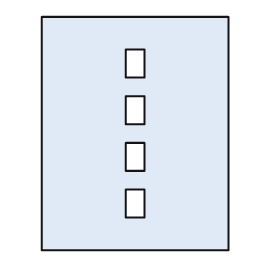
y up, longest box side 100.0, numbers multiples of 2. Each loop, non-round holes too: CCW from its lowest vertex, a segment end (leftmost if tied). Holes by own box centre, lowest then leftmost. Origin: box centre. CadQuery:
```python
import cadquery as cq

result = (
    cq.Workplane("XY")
    .moveTo(-40.0, -50.0)
    .lineTo(40.0, -50.0)
    .lineTo(40.0, 50.0)
    .lineTo(-40.0, 50.0)
    .close()
    .moveTo(-4.0, -36.0)
    .lineTo(4.0, -36.0)
    .lineTo(4.0, -24.0)
    .lineTo(-4.0, -24.0)
    .close()
    .moveTo(-4.0, -16.0)
    .lineTo(4.0, -16.0)
    .lineTo(4.0, -4.0)
    .lineTo(-4.0, -4.0)
    .close()
    .moveTo(-4.0, 4.0)
    .lineTo(4.0, 4.0)
    .lineTo(4.0, 16.0)
    .lineTo(-4.0, 16.0)
    .close()
    .moveTo(-4.0, 24.0)
    .lineTo(4.0, 24.0)
    .lineTo(4.0, 36.0)
    .lineTo(-4.0, 36.0)
    .close()
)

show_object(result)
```